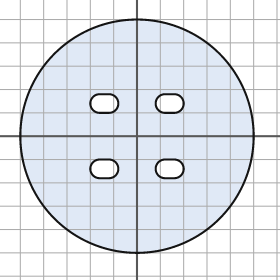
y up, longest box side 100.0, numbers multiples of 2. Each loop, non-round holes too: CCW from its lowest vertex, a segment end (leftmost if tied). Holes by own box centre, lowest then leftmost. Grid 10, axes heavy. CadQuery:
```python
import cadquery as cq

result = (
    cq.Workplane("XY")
    .moveTo(0.0, 0.0)
    .circle(50.0)
    .moveTo(-16.0, -18.0)
    .lineTo(-12.0, -18.0)
    .threePointArc((-8.0, -14.0), (-12.0, -10.0))
    .lineTo(-16.0, -10.0)
    .threePointArc((-20.0, -14.0), (-16.0, -18.0))
    .close()
    .moveTo(12.0, -18.0)
    .lineTo(16.0, -18.0)
    .threePointArc((20.0, -14.0), (16.0, -10.0))
    .lineTo(12.0, -10.0)
    .threePointArc((8.0, -14.0), (12.0, -18.0))
    .close()
    .moveTo(-16.0, 10.0)
    .lineTo(-12.0, 10.0)
    .threePointArc((-8.0, 14.0), (-12.0, 18.0))
    .lineTo(-16.0, 18.0)
    .threePointArc((-20.0, 14.0), (-16.0, 10.0))
    .close()
    .moveTo(12.0, 10.0)
    .lineTo(16.0, 10.0)
    .threePointArc((20.0, 14.0), (16.0, 18.0))
    .lineTo(12.0, 18.0)
    .threePointArc((8.0, 14.0), (12.0, 10.0))
    .close()
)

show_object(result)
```